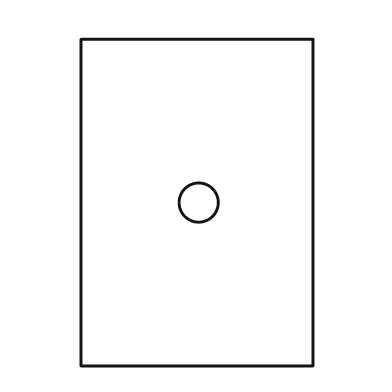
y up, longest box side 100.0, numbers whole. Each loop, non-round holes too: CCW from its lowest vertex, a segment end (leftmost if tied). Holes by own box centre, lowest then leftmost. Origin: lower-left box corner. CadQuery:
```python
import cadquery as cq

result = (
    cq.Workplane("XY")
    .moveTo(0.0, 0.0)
    .lineTo(71.0, 0.0)
    .lineTo(71.0, 100.0)
    .lineTo(0.0, 100.0)
    .close()
    .moveTo(36.0, 50.0)
    .circle(6.0)
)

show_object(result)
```